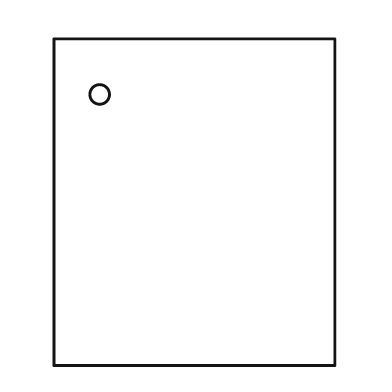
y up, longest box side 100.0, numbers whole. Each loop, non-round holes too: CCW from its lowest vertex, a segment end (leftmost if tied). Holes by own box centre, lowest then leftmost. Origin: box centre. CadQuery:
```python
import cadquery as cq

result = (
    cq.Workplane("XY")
    .moveTo(-43.0, -50.0)
    .lineTo(43.0, -50.0)
    .lineTo(43.0, 50.0)
    .lineTo(-43.0, 50.0)
    .close()
    .moveTo(-29.0, 33.0)
    .circle(3.0)
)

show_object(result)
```